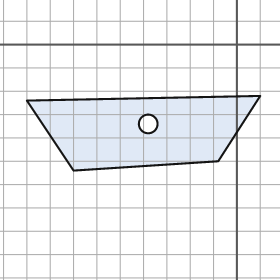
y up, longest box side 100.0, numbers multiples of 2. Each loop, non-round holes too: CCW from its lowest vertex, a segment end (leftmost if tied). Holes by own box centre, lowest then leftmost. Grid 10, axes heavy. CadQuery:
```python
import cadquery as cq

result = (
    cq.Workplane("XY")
    .moveTo(-70.0, -54.0)
    .lineTo(-8.0, -50.0)
    .lineTo(10.0, -22.0)
    .lineTo(-90.0, -24.0)
    .close()
    .moveTo(-38.0, -34.0)
    .circle(4.0)
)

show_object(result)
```